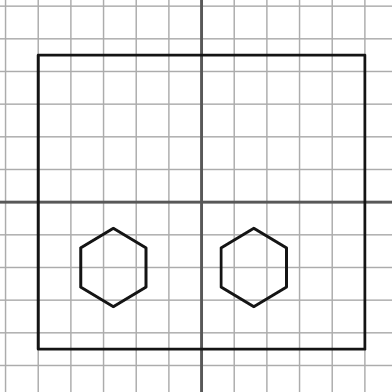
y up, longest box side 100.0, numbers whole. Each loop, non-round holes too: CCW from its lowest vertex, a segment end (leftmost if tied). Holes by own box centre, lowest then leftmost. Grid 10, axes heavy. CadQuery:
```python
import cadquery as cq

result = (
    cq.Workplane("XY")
    .moveTo(-50.0, -45.0)
    .lineTo(50.0, -45.0)
    .lineTo(50.0, 45.0)
    .lineTo(-50.0, 45.0)
    .close()
    .moveTo(-27.0, -32.0)
    .lineTo(-17.0, -26.0)
    .lineTo(-17.0, -14.0)
    .lineTo(-27.0, -8.0)
    .lineTo(-37.0, -14.0)
    .lineTo(-37.0, -26.0)
    .close()
    .moveTo(16.0, -32.0)
    .lineTo(26.0, -26.0)
    .lineTo(26.0, -14.0)
    .lineTo(16.0, -8.0)
    .lineTo(6.0, -14.0)
    .lineTo(6.0, -26.0)
    .close()
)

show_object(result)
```